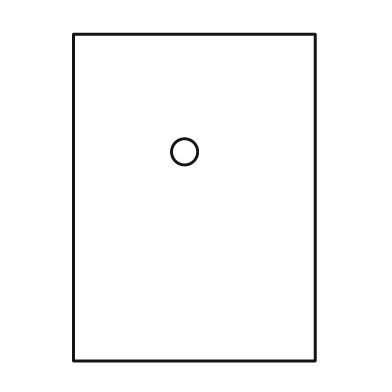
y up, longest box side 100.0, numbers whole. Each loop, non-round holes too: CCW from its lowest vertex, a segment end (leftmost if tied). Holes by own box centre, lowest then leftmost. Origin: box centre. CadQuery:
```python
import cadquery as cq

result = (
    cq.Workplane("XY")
    .moveTo(-37.0, -50.0)
    .lineTo(37.0, -50.0)
    .lineTo(37.0, 50.0)
    .lineTo(-37.0, 50.0)
    .close()
    .moveTo(-3.0, 14.0)
    .circle(4.0)
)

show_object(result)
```